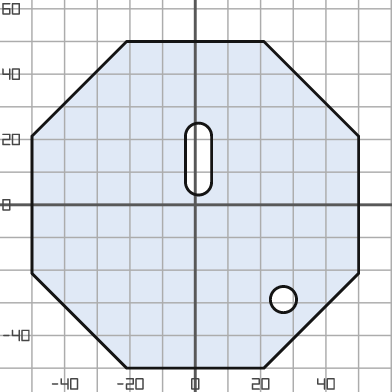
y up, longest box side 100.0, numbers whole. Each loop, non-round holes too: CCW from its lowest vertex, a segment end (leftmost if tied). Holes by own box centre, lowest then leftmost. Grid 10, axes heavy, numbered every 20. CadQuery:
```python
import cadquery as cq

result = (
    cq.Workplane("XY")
    .moveTo(-21.0, -50.0)
    .lineTo(21.0, -50.0)
    .lineTo(50.0, -21.0)
    .lineTo(50.0, 21.0)
    .lineTo(21.0, 50.0)
    .lineTo(-21.0, 50.0)
    .lineTo(-50.0, 21.0)
    .lineTo(-50.0, -21.0)
    .close()
    .moveTo(27.0, -29.0)
    .circle(4.0)
    .moveTo(-3.0, 7.0)
    .threePointArc((1.0, 3.0), (5.0, 7.0))
    .lineTo(5.0, 21.0)
    .threePointArc((1.0, 25.0), (-3.0, 21.0))
    .close()
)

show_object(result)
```